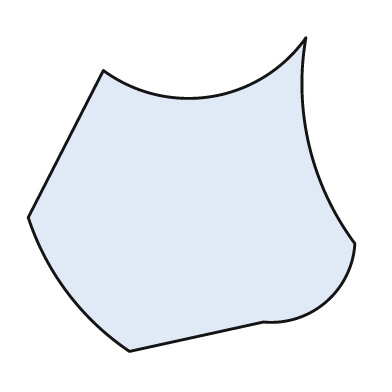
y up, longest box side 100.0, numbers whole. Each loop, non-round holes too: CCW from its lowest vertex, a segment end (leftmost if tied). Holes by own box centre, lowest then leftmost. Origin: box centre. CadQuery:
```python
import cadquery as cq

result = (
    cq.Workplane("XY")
    .moveTo(-19.0, -48.0)
    .lineTo(22.0, -39.0)
    .threePointArc((41.0, -33.0), (50.0, -15.0))
    .threePointArc((36.0, 15.0), (35.0, 48.0))
    .threePointArc((6.0, 30.0), (-27.0, 38.0))
    .lineTo(-50.0, -7.0)
    .threePointArc((-38.0, -30.0), (-19.0, -48.0))
    .close()
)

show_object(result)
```